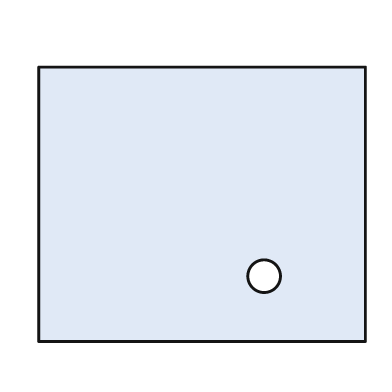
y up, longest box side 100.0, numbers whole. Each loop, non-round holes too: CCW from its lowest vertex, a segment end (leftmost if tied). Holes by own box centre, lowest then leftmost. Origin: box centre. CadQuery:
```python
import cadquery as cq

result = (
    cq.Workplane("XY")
    .moveTo(-50.0, -42.0)
    .lineTo(50.0, -42.0)
    .lineTo(50.0, 42.0)
    .lineTo(-50.0, 42.0)
    .close()
    .moveTo(19.0, -22.0)
    .circle(5.0)
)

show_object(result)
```